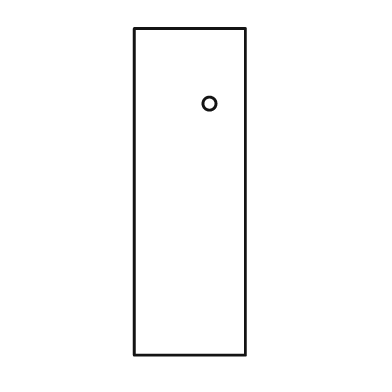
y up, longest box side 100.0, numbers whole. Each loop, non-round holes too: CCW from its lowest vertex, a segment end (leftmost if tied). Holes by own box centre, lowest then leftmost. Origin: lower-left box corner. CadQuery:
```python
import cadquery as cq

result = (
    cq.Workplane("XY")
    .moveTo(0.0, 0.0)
    .lineTo(34.0, 0.0)
    .lineTo(34.0, 100.0)
    .lineTo(0.0, 100.0)
    .close()
    .moveTo(23.0, 77.0)
    .circle(2.0)
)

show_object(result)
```